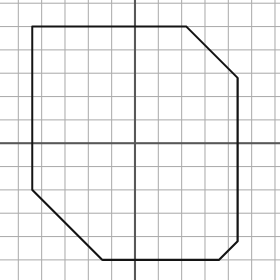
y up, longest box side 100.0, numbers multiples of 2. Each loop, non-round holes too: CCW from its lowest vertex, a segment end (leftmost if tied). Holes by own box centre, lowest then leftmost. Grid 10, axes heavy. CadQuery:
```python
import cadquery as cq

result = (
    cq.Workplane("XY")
    .moveTo(-14.0, -50.0)
    .lineTo(36.0, -50.0)
    .lineTo(44.0, -42.0)
    .lineTo(44.0, 28.0)
    .lineTo(22.0, 50.0)
    .lineTo(-44.0, 50.0)
    .lineTo(-44.0, -20.0)
    .close()
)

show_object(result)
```